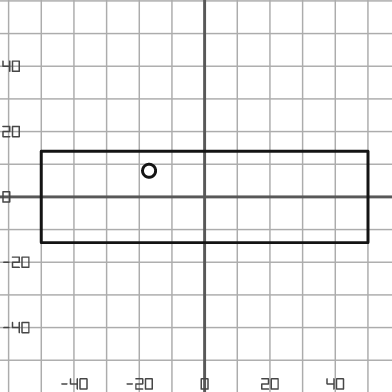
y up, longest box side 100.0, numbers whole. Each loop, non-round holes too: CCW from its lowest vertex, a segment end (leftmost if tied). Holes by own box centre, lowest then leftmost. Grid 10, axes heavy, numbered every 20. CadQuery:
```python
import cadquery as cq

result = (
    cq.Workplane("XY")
    .moveTo(-50.0, -14.0)
    .lineTo(50.0, -14.0)
    .lineTo(50.0, 14.0)
    .lineTo(-50.0, 14.0)
    .close()
    .moveTo(-17.0, 8.0)
    .circle(2.0)
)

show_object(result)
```